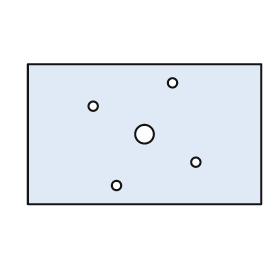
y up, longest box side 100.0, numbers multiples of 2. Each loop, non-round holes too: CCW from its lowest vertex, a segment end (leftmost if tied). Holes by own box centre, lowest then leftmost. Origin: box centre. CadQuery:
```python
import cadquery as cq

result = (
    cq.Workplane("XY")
    .moveTo(-50.0, -30.0)
    .lineTo(50.0, -30.0)
    .lineTo(50.0, 30.0)
    .lineTo(-50.0, 30.0)
    .close()
    .moveTo(-12.0, -22.0)
    .circle(2.0)
    .moveTo(22.0, -12.0)
    .circle(2.0)
    .moveTo(0.0, 0.0)
    .circle(4.0)
    .moveTo(-22.0, 12.0)
    .circle(2.0)
    .moveTo(12.0, 22.0)
    .circle(2.0)
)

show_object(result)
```